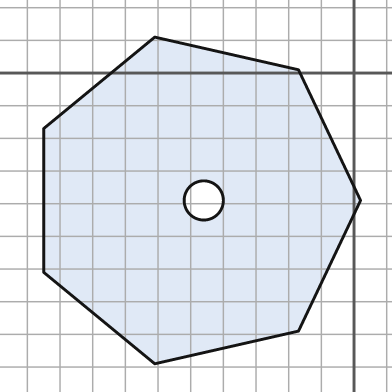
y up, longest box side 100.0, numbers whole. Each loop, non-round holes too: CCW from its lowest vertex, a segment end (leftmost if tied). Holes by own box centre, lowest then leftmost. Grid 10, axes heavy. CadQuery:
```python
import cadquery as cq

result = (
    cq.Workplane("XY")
    .moveTo(-61.0, -89.0)
    .lineTo(-17.0, -79.0)
    .lineTo(2.0, -39.0)
    .lineTo(-17.0, 1.0)
    .lineTo(-61.0, 11.0)
    .lineTo(-95.0, -17.0)
    .lineTo(-95.0, -61.0)
    .close()
    .moveTo(-46.0, -39.0)
    .circle(6.0)
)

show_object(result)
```